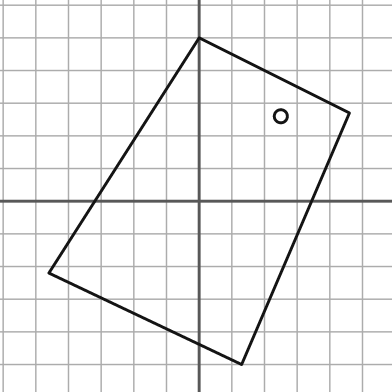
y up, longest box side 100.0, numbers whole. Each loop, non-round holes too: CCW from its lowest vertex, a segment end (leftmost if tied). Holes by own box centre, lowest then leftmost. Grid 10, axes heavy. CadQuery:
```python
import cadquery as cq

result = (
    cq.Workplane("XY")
    .moveTo(13.0, -50.0)
    .lineTo(46.0, 27.0)
    .lineTo(0.0, 50.0)
    .lineTo(-46.0, -22.0)
    .close()
    .moveTo(25.0, 26.0)
    .circle(2.0)
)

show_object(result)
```